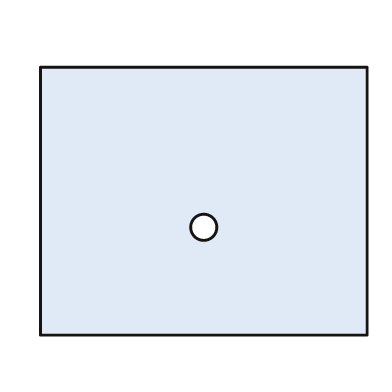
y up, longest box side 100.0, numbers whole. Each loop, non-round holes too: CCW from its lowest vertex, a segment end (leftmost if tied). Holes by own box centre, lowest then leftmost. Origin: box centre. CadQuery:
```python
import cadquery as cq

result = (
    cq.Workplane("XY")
    .moveTo(-50.0, -41.0)
    .lineTo(50.0, -41.0)
    .lineTo(50.0, 41.0)
    .lineTo(-50.0, 41.0)
    .close()
    .moveTo(0.0, -8.0)
    .circle(4.0)
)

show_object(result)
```